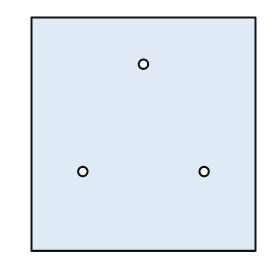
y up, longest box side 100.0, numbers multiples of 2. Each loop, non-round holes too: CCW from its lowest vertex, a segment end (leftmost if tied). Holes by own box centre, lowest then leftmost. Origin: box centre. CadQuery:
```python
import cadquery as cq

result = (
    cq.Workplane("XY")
    .moveTo(-48.0, -50.0)
    .lineTo(48.0, -50.0)
    .lineTo(48.0, 50.0)
    .lineTo(-48.0, 50.0)
    .close()
    .moveTo(-26.0, -16.0)
    .circle(2.0)
    .moveTo(26.0, -16.0)
    .circle(2.0)
    .moveTo(0.0, 30.0)
    .circle(2.0)
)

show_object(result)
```